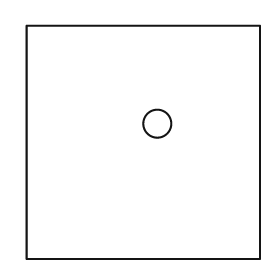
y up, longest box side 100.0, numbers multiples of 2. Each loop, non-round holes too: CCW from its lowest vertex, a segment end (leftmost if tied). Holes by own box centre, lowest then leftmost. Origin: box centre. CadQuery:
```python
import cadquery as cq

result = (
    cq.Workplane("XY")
    .moveTo(-50.0, -50.0)
    .lineTo(50.0, -50.0)
    .lineTo(50.0, 50.0)
    .lineTo(-50.0, 50.0)
    .close()
    .moveTo(6.0, 8.0)
    .circle(6.0)
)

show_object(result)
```